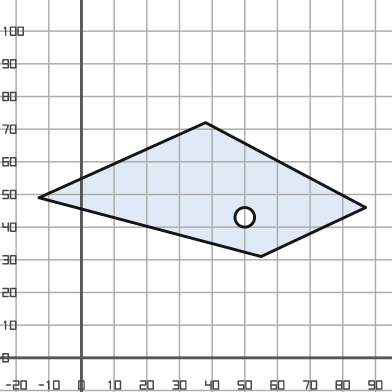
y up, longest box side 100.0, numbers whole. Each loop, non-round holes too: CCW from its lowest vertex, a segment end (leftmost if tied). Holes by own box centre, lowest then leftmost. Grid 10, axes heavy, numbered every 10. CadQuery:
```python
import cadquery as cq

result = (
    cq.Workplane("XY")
    .moveTo(55.0, 31.0)
    .lineTo(87.0, 46.0)
    .lineTo(38.0, 72.0)
    .lineTo(-13.0, 49.0)
    .close()
    .moveTo(50.0, 43.0)
    .circle(3.0)
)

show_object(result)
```